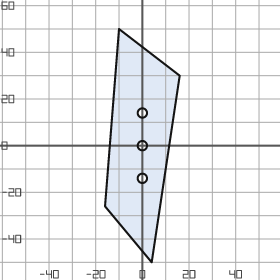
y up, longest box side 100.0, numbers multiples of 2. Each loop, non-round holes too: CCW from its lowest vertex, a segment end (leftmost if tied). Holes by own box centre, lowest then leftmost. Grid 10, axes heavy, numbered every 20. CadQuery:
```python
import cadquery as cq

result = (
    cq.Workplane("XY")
    .moveTo(4.0, -50.0)
    .lineTo(16.0, 30.0)
    .lineTo(-10.0, 50.0)
    .lineTo(-16.0, -26.0)
    .close()
    .moveTo(0.0, -14.0)
    .circle(2.0)
    .moveTo(0.0, 0.0)
    .circle(2.0)
    .moveTo(0.0, 14.0)
    .circle(2.0)
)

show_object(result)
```